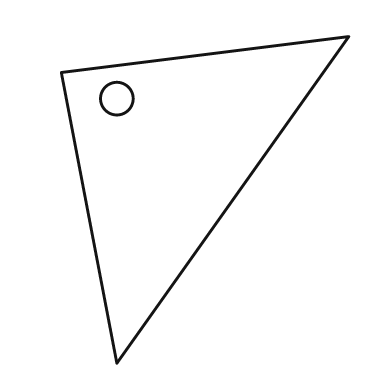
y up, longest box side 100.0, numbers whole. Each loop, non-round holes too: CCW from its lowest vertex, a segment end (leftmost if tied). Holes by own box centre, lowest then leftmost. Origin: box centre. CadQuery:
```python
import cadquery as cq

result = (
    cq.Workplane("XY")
    .moveTo(-27.0, -50.0)
    .lineTo(44.0, 50.0)
    .lineTo(-44.0, 39.0)
    .close()
    .moveTo(-27.0, 31.0)
    .circle(5.0)
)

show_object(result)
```